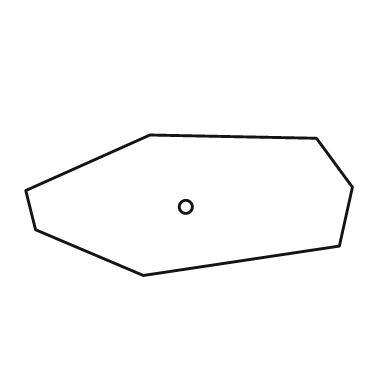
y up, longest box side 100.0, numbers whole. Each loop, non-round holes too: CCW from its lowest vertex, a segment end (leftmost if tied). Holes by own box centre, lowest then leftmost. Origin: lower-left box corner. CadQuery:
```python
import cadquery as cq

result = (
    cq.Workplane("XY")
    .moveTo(36.0, 0.0)
    .lineTo(96.0, 9.0)
    .lineTo(100.0, 27.0)
    .lineTo(89.0, 42.0)
    .lineTo(38.0, 43.0)
    .lineTo(0.0, 26.0)
    .lineTo(3.0, 14.0)
    .close()
    .moveTo(49.0, 21.0)
    .circle(2.0)
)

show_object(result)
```